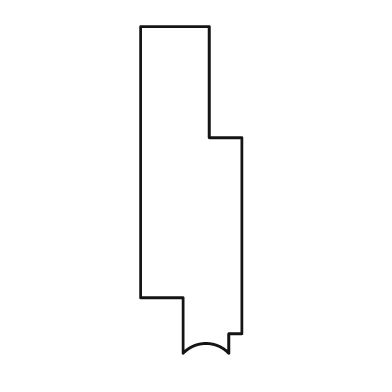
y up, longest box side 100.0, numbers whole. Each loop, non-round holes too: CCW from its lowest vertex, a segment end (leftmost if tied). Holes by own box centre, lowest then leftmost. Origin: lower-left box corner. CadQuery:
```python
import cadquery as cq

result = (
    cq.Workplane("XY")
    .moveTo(13.0, 0.0)
    .threePointArc((20.0, 3.0), (27.0, 0.0))
    .lineTo(27.0, 6.0)
    .lineTo(31.0, 6.0)
    .lineTo(31.0, 66.0)
    .lineTo(21.0, 66.0)
    .lineTo(21.0, 100.0)
    .lineTo(0.0, 100.0)
    .lineTo(0.0, 17.0)
    .lineTo(13.0, 17.0)
    .close()
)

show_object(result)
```